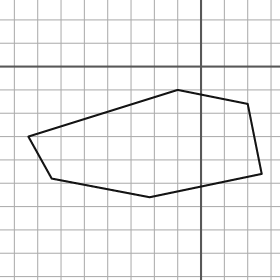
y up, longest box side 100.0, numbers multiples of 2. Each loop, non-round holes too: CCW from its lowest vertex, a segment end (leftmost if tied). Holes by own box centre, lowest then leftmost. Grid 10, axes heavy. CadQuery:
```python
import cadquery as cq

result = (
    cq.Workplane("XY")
    .moveTo(-22.0, -56.0)
    .lineTo(26.0, -46.0)
    .lineTo(20.0, -16.0)
    .lineTo(-10.0, -10.0)
    .lineTo(-74.0, -30.0)
    .lineTo(-64.0, -48.0)
    .close()
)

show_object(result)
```